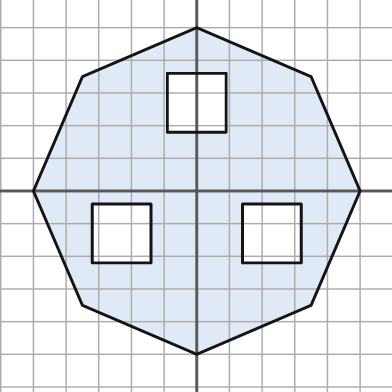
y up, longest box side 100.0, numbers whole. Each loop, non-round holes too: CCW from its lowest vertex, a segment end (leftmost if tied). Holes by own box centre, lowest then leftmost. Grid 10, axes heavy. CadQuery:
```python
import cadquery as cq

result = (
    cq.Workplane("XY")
    .moveTo(0.0, -50.0)
    .lineTo(35.0, -35.0)
    .lineTo(50.0, 0.0)
    .lineTo(35.0, 35.0)
    .lineTo(0.0, 50.0)
    .lineTo(-35.0, 35.0)
    .lineTo(-50.0, 0.0)
    .lineTo(-35.0, -35.0)
    .close()
    .moveTo(-32.0, -22.0)
    .lineTo(-14.0, -22.0)
    .lineTo(-14.0, -4.0)
    .lineTo(-32.0, -4.0)
    .close()
    .moveTo(14.0, -22.0)
    .lineTo(32.0, -22.0)
    .lineTo(32.0, -4.0)
    .lineTo(14.0, -4.0)
    .close()
    .moveTo(-9.0, 18.0)
    .lineTo(9.0, 18.0)
    .lineTo(9.0, 36.0)
    .lineTo(-9.0, 36.0)
    .close()
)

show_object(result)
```